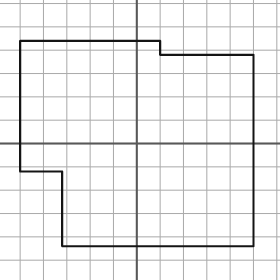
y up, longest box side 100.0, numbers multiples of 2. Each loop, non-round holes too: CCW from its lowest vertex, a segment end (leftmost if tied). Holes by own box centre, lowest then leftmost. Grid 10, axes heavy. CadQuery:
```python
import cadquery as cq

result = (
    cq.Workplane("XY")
    .moveTo(-32.0, -44.0)
    .lineTo(50.0, -44.0)
    .lineTo(50.0, 38.0)
    .lineTo(10.0, 38.0)
    .lineTo(10.0, 44.0)
    .lineTo(-50.0, 44.0)
    .lineTo(-50.0, -12.0)
    .lineTo(-32.0, -12.0)
    .close()
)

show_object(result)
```